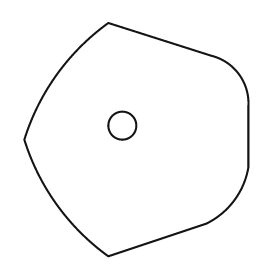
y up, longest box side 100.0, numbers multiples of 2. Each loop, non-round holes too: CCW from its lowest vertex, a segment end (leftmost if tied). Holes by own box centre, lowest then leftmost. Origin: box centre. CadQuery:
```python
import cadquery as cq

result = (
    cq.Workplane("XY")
    .moveTo(-12.0, -50.0)
    .lineTo(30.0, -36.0)
    .threePointArc((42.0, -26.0), (48.0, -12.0))
    .lineTo(48.0, 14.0)
    .threePointArc((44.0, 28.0), (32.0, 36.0))
    .lineTo(-12.0, 50.0)
    .threePointArc((-34.0, 28.0), (-48.0, 0.0))
    .threePointArc((-34.0, -28.0), (-12.0, -50.0))
    .close()
    .moveTo(-6.0, 6.0)
    .circle(6.0)
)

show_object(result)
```